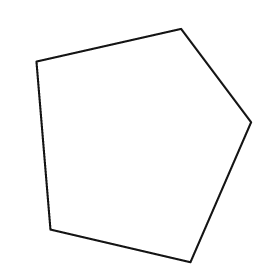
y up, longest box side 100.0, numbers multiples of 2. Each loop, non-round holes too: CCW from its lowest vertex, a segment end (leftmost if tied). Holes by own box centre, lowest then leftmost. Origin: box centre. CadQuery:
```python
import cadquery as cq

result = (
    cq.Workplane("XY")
    .moveTo(20.0, -50.0)
    .lineTo(46.0, 10.0)
    .lineTo(16.0, 50.0)
    .lineTo(-46.0, 36.0)
    .lineTo(-40.0, -36.0)
    .close()
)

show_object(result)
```